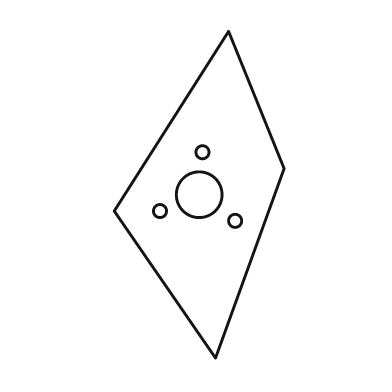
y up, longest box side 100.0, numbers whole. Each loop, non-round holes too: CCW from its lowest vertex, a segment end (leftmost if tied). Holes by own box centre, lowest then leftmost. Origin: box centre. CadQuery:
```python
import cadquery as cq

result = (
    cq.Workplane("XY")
    .moveTo(5.0, -50.0)
    .lineTo(26.0, 8.0)
    .lineTo(9.0, 50.0)
    .lineTo(-26.0, -5.0)
    .close()
    .moveTo(11.0, -8.0)
    .circle(2.0)
    .moveTo(-12.0, -5.0)
    .circle(2.0)
    .moveTo(0.0, 0.0)
    .circle(7.0)
    .moveTo(1.0, 13.0)
    .circle(2.0)
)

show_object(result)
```